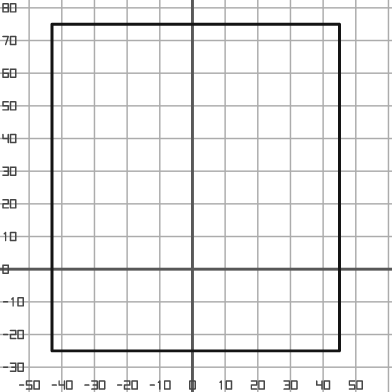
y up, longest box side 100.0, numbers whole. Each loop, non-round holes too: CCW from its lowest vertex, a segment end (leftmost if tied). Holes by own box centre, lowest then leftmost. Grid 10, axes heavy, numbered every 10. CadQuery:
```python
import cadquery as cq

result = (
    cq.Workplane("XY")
    .moveTo(-43.0, -25.0)
    .lineTo(45.0, -25.0)
    .lineTo(45.0, 75.0)
    .lineTo(-43.0, 75.0)
    .close()
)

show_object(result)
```